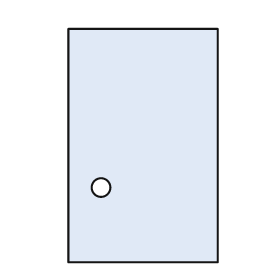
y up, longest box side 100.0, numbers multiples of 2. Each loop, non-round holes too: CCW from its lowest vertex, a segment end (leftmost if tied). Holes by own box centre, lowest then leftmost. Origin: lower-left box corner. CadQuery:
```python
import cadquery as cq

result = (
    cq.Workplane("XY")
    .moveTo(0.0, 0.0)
    .lineTo(64.0, 0.0)
    .lineTo(64.0, 100.0)
    .lineTo(0.0, 100.0)
    .close()
    .moveTo(14.0, 32.0)
    .circle(4.0)
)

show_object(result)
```